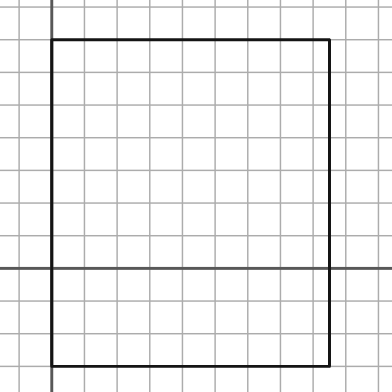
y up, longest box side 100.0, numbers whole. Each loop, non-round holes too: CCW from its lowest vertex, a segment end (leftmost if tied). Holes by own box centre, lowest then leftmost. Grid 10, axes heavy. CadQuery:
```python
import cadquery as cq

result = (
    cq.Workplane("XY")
    .moveTo(0.0, -30.0)
    .lineTo(85.0, -30.0)
    .lineTo(85.0, 70.0)
    .lineTo(0.0, 70.0)
    .close()
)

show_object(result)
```